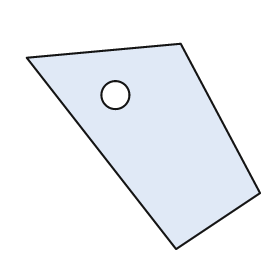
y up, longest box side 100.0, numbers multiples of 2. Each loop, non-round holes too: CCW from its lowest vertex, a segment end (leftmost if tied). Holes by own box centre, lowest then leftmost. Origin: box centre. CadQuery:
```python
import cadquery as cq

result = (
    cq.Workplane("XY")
    .moveTo(14.0, -44.0)
    .lineTo(50.0, -20.0)
    .lineTo(16.0, 44.0)
    .lineTo(-50.0, 38.0)
    .close()
    .moveTo(-12.0, 22.0)
    .circle(6.0)
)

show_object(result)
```